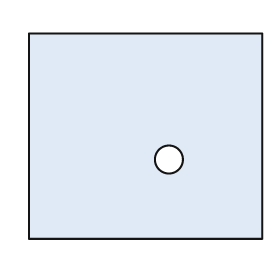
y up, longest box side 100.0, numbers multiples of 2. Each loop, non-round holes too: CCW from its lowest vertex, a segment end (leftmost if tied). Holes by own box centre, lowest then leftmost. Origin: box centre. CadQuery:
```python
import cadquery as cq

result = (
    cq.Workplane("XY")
    .moveTo(-50.0, -44.0)
    .lineTo(50.0, -44.0)
    .lineTo(50.0, 44.0)
    .lineTo(-50.0, 44.0)
    .close()
    .moveTo(10.0, -10.0)
    .circle(6.0)
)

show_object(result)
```